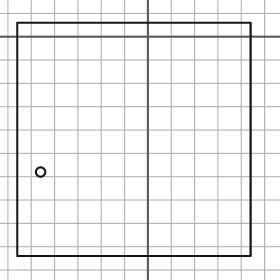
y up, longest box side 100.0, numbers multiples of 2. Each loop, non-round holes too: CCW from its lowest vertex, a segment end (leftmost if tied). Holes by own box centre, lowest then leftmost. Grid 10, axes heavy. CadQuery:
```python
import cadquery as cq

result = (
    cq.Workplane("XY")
    .moveTo(-56.0, -94.0)
    .lineTo(44.0, -94.0)
    .lineTo(44.0, 6.0)
    .lineTo(-56.0, 6.0)
    .close()
    .moveTo(-46.0, -58.0)
    .circle(2.0)
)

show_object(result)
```